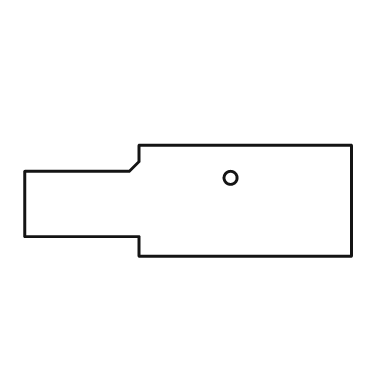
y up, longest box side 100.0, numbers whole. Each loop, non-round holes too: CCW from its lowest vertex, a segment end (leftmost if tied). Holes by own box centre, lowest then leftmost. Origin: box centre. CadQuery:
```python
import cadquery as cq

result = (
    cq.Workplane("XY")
    .moveTo(-15.0, -17.0)
    .lineTo(50.0, -17.0)
    .lineTo(50.0, 17.0)
    .lineTo(-15.0, 17.0)
    .lineTo(-15.0, 12.0)
    .lineTo(-18.0, 9.0)
    .lineTo(-50.0, 9.0)
    .lineTo(-50.0, -11.0)
    .lineTo(-15.0, -11.0)
    .close()
    .moveTo(13.0, 7.0)
    .circle(2.0)
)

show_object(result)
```